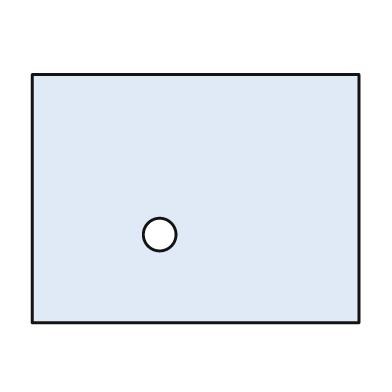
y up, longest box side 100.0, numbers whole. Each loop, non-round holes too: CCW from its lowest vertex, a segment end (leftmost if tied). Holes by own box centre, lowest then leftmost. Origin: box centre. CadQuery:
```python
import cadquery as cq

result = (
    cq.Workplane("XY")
    .moveTo(-50.0, -38.0)
    .lineTo(50.0, -38.0)
    .lineTo(50.0, 38.0)
    .lineTo(-50.0, 38.0)
    .close()
    .moveTo(-11.0, -11.0)
    .circle(5.0)
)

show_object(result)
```